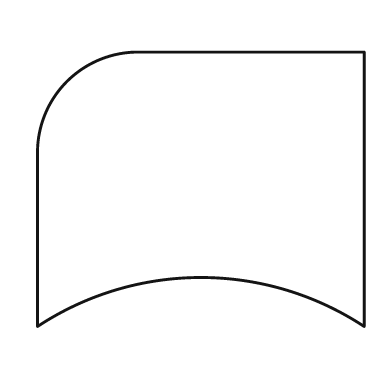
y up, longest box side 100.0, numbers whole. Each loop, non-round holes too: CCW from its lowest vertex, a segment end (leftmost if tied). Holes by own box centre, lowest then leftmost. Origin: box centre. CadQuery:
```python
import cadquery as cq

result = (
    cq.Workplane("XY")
    .moveTo(-50.0, -42.0)
    .threePointArc((0.0, -27.0), (50.0, -42.0))
    .lineTo(50.0, 42.0)
    .lineTo(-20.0, 42.0)
    .threePointArc((-41.0, 33.0), (-50.0, 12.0))
    .close()
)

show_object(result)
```